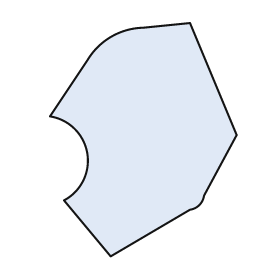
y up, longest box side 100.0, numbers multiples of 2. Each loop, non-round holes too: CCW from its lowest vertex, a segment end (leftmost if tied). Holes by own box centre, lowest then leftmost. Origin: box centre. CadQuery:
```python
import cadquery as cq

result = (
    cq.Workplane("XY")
    .moveTo(-14.0, -50.0)
    .lineTo(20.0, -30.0)
    .threePointArc((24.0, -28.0), (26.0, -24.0))
    .lineTo(40.0, 2.0)
    .lineTo(20.0, 50.0)
    .lineTo(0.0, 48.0)
    .threePointArc((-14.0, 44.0), (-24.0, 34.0))
    .lineTo(-40.0, 10.0)
    .threePointArc((-24.0, -6.0), (-34.0, -26.0))
    .close()
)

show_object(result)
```